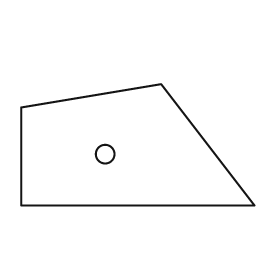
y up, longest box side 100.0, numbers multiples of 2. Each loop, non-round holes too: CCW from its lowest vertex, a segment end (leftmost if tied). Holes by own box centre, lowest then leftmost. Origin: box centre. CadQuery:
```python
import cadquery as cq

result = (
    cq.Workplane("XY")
    .moveTo(-50.0, -26.0)
    .lineTo(50.0, -26.0)
    .lineTo(10.0, 26.0)
    .lineTo(-50.0, 16.0)
    .close()
    .moveTo(-14.0, -4.0)
    .circle(4.0)
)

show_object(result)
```